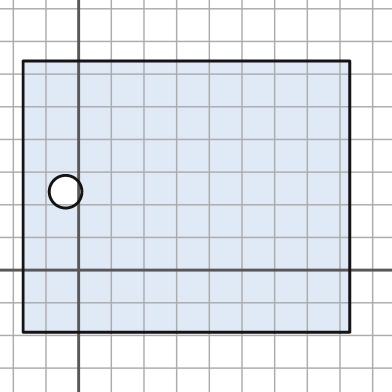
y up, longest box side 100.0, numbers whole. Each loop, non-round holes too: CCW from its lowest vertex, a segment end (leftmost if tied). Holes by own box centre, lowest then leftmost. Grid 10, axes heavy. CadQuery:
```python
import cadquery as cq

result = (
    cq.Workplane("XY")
    .moveTo(-17.0, -19.0)
    .lineTo(83.0, -19.0)
    .lineTo(83.0, 64.0)
    .lineTo(-17.0, 64.0)
    .close()
    .moveTo(-4.0, 24.0)
    .circle(5.0)
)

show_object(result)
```